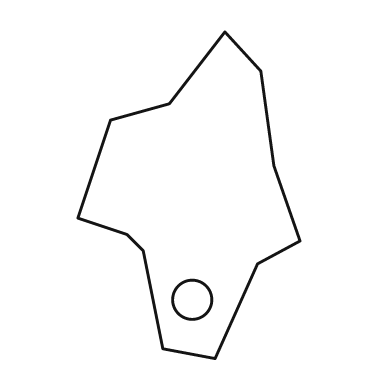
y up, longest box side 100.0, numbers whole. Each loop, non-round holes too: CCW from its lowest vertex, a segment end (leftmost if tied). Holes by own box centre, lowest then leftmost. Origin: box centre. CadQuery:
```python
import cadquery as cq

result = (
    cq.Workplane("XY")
    .moveTo(8.0, -50.0)
    .lineTo(21.0, -21.0)
    .lineTo(34.0, -14.0)
    .lineTo(26.0, 9.0)
    .lineTo(22.0, 38.0)
    .lineTo(11.0, 50.0)
    .lineTo(-6.0, 28.0)
    .lineTo(-24.0, 23.0)
    .lineTo(-34.0, -7.0)
    .lineTo(-19.0, -12.0)
    .lineTo(-14.0, -17.0)
    .lineTo(-8.0, -47.0)
    .close()
    .moveTo(1.0, -32.0)
    .circle(6.0)
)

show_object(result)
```